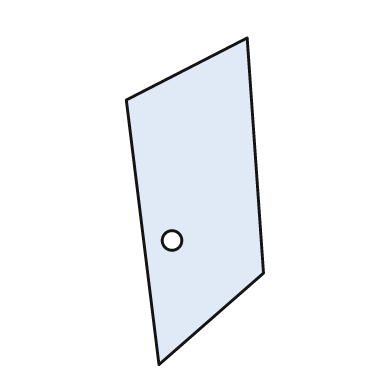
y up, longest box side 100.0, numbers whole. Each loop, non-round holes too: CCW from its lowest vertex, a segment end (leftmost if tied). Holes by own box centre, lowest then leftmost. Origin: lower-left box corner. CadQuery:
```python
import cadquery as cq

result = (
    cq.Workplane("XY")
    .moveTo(10.0, 0.0)
    .lineTo(42.0, 28.0)
    .lineTo(37.0, 100.0)
    .lineTo(0.0, 81.0)
    .close()
    .moveTo(14.0, 38.0)
    .circle(3.0)
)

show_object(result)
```